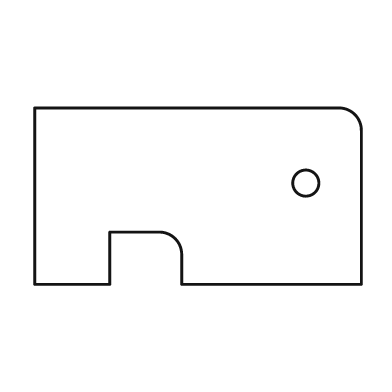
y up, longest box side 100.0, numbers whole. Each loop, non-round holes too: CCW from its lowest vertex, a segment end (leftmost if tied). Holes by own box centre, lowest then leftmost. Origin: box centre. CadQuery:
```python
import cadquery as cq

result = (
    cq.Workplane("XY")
    .moveTo(-50.0, -27.0)
    .lineTo(-27.0, -27.0)
    .lineTo(-27.0, -11.0)
    .lineTo(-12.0, -11.0)
    .threePointArc((-7.0, -13.0), (-5.0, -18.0))
    .lineTo(-5.0, -27.0)
    .lineTo(50.0, -27.0)
    .lineTo(50.0, 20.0)
    .threePointArc((48.0, 25.0), (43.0, 27.0))
    .lineTo(-50.0, 27.0)
    .close()
    .moveTo(33.0, 4.0)
    .circle(4.0)
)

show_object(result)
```